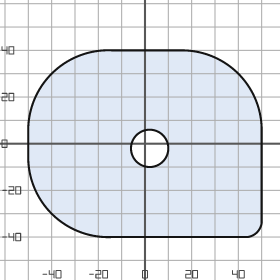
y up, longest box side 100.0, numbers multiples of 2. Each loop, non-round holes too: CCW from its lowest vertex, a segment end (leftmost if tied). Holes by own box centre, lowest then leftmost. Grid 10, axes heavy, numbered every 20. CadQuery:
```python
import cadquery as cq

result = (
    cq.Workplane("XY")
    .moveTo(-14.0, -40.0)
    .lineTo(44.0, -40.0)
    .threePointArc((48.0, -38.0), (50.0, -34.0))
    .lineTo(50.0, 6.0)
    .threePointArc((40.0, 30.0), (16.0, 40.0))
    .lineTo(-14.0, 40.0)
    .threePointArc((-40.0, 30.0), (-50.0, 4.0))
    .lineTo(-50.0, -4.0)
    .threePointArc((-40.0, -30.0), (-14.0, -40.0))
    .close()
    .moveTo(2.0, -2.0)
    .circle(8.0)
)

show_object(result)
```